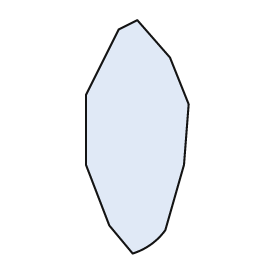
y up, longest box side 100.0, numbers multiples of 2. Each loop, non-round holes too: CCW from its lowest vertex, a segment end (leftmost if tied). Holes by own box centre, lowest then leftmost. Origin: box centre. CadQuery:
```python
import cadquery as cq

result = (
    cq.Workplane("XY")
    .moveTo(-2.0, -50.0)
    .threePointArc((6.0, -46.0), (12.0, -40.0))
    .lineTo(20.0, -12.0)
    .lineTo(22.0, 14.0)
    .lineTo(14.0, 34.0)
    .lineTo(0.0, 50.0)
    .lineTo(-8.0, 46.0)
    .lineTo(-22.0, 18.0)
    .lineTo(-22.0, -12.0)
    .lineTo(-12.0, -38.0)
    .close()
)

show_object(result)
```